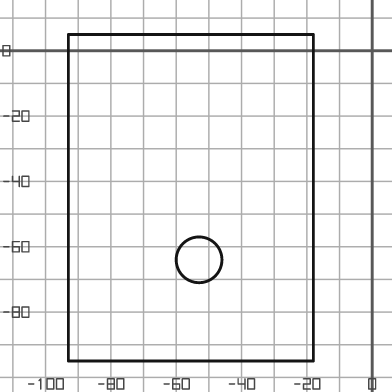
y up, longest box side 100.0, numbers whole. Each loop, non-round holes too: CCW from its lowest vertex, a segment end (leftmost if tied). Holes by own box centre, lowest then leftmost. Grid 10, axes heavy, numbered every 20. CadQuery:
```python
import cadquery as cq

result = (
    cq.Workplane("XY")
    .moveTo(-93.0, -95.0)
    .lineTo(-18.0, -95.0)
    .lineTo(-18.0, 5.0)
    .lineTo(-93.0, 5.0)
    .close()
    .moveTo(-53.0, -64.0)
    .circle(7.0)
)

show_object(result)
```